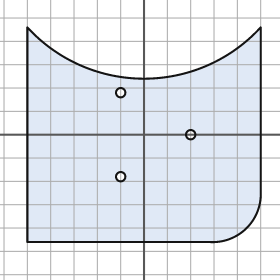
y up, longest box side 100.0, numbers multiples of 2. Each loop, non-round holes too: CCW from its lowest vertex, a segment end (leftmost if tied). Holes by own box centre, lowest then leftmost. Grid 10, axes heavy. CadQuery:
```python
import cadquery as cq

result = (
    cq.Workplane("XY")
    .moveTo(-50.0, -46.0)
    .lineTo(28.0, -46.0)
    .threePointArc((44.0, -40.0), (50.0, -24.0))
    .lineTo(50.0, 46.0)
    .threePointArc((0.0, 24.0), (-50.0, 46.0))
    .close()
    .moveTo(-10.0, -18.0)
    .circle(2.0)
    .moveTo(20.0, 0.0)
    .circle(2.0)
    .moveTo(-10.0, 18.0)
    .circle(2.0)
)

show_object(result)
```